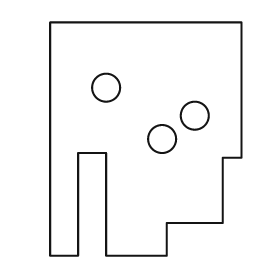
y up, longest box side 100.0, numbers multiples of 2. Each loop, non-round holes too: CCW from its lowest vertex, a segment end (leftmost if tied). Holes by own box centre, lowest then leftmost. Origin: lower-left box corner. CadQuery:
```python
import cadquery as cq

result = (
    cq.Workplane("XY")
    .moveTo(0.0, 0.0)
    .lineTo(12.0, 0.0)
    .lineTo(12.0, 44.0)
    .lineTo(24.0, 44.0)
    .lineTo(24.0, 0.0)
    .lineTo(50.0, 0.0)
    .lineTo(50.0, 14.0)
    .lineTo(74.0, 14.0)
    .lineTo(74.0, 42.0)
    .lineTo(82.0, 42.0)
    .lineTo(82.0, 100.0)
    .lineTo(0.0, 100.0)
    .close()
    .moveTo(48.0, 50.0)
    .circle(6.0)
    .moveTo(62.0, 60.0)
    .circle(6.0)
    .moveTo(24.0, 72.0)
    .circle(6.0)
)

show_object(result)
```